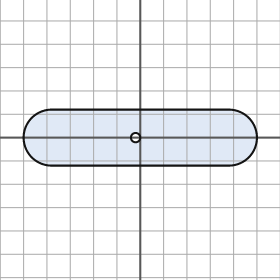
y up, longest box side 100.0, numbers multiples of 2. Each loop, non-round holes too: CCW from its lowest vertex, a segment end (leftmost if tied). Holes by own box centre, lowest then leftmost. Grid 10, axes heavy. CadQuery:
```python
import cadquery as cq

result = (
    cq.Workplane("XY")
    .moveTo(-38.0, -12.0)
    .lineTo(38.0, -12.0)
    .threePointArc((50.0, 0.0), (38.0, 12.0))
    .lineTo(-38.0, 12.0)
    .threePointArc((-50.0, 0.0), (-38.0, -12.0))
    .close()
    .moveTo(-2.0, 0.0)
    .circle(2.0)
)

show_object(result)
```